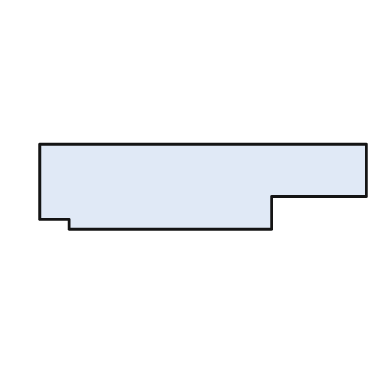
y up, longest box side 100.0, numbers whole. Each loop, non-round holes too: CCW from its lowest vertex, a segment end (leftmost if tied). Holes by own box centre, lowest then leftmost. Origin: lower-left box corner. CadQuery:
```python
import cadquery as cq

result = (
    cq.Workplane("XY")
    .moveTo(9.0, 0.0)
    .lineTo(71.0, 0.0)
    .lineTo(71.0, 10.0)
    .lineTo(100.0, 10.0)
    .lineTo(100.0, 26.0)
    .lineTo(0.0, 26.0)
    .lineTo(0.0, 3.0)
    .lineTo(9.0, 3.0)
    .close()
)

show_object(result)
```